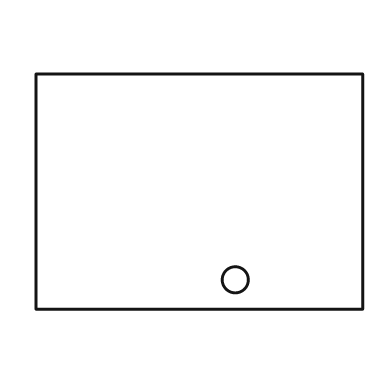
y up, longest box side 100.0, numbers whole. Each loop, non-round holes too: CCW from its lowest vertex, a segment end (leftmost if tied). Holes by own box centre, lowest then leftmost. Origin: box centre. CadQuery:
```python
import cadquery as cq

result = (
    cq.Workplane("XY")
    .moveTo(-50.0, -36.0)
    .lineTo(50.0, -36.0)
    .lineTo(50.0, 36.0)
    .lineTo(-50.0, 36.0)
    .close()
    .moveTo(11.0, -27.0)
    .circle(4.0)
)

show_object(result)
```